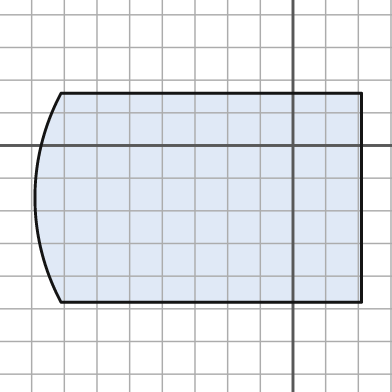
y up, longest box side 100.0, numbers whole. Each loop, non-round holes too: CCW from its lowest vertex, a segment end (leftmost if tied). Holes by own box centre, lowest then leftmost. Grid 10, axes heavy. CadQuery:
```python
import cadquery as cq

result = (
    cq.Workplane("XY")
    .moveTo(-71.0, -48.0)
    .lineTo(21.0, -48.0)
    .lineTo(21.0, 16.0)
    .lineTo(-71.0, 16.0)
    .threePointArc((-79.0, -16.0), (-71.0, -48.0))
    .close()
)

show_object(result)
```